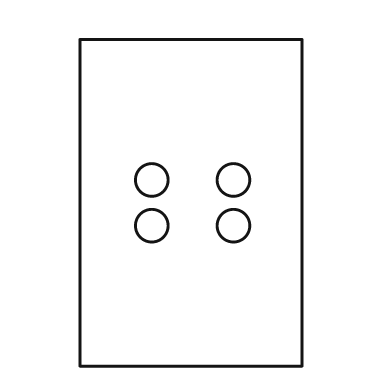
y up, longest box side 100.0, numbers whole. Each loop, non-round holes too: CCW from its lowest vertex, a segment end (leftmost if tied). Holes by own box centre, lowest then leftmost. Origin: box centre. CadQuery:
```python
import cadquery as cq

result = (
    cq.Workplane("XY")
    .moveTo(-34.0, -50.0)
    .lineTo(34.0, -50.0)
    .lineTo(34.0, 50.0)
    .lineTo(-34.0, 50.0)
    .close()
    .moveTo(-12.0, -7.0)
    .circle(5.0)
    .moveTo(13.0, -7.0)
    .circle(5.0)
    .moveTo(-12.0, 7.0)
    .circle(5.0)
    .moveTo(13.0, 7.0)
    .circle(5.0)
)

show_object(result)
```